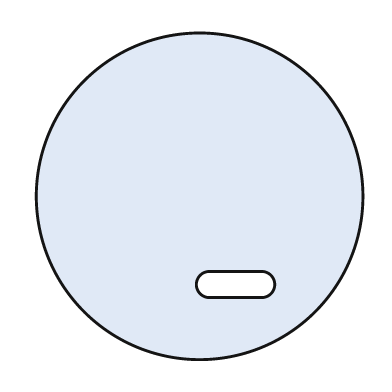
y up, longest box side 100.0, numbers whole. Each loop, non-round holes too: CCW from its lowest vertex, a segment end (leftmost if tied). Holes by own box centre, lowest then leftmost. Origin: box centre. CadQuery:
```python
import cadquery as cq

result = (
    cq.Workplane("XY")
    .moveTo(0.0, 0.0)
    .circle(50.0)
    .moveTo(3.0, -31.0)
    .lineTo(19.0, -31.0)
    .threePointArc((23.0, -27.0), (19.0, -23.0))
    .lineTo(3.0, -23.0)
    .threePointArc((-1.0, -27.0), (3.0, -31.0))
    .close()
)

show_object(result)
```